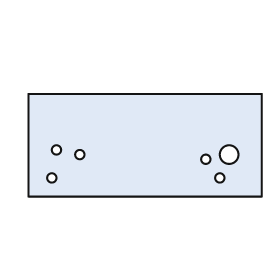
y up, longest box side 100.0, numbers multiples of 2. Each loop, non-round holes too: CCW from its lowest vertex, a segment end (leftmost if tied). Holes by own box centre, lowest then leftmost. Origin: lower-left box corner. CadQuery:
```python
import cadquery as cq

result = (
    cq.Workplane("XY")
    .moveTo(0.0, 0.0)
    .lineTo(100.0, 0.0)
    .lineTo(100.0, 44.0)
    .lineTo(0.0, 44.0)
    .close()
    .moveTo(10.0, 8.0)
    .circle(2.0)
    .moveTo(82.0, 8.0)
    .circle(2.0)
    .moveTo(76.0, 16.0)
    .circle(2.0)
    .moveTo(22.0, 18.0)
    .circle(2.0)
    .moveTo(86.0, 18.0)
    .circle(4.0)
    .moveTo(12.0, 20.0)
    .circle(2.0)
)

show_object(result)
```